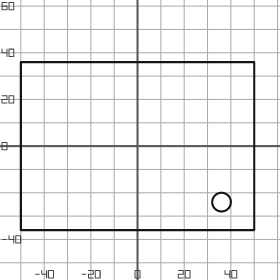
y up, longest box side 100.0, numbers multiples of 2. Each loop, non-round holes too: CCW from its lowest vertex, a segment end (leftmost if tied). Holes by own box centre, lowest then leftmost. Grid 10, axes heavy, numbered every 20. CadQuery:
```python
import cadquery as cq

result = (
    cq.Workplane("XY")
    .moveTo(-50.0, -36.0)
    .lineTo(50.0, -36.0)
    .lineTo(50.0, 36.0)
    .lineTo(-50.0, 36.0)
    .close()
    .moveTo(36.0, -24.0)
    .circle(4.0)
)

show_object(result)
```